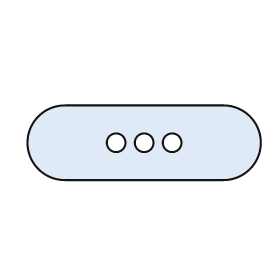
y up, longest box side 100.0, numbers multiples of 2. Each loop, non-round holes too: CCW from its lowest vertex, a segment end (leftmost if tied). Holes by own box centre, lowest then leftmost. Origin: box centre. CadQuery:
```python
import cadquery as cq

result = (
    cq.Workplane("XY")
    .moveTo(-34.0, -16.0)
    .lineTo(34.0, -16.0)
    .threePointArc((50.0, 0.0), (34.0, 16.0))
    .lineTo(-34.0, 16.0)
    .threePointArc((-50.0, 0.0), (-34.0, -16.0))
    .close()
    .moveTo(-12.0, 0.0)
    .circle(4.0)
    .moveTo(0.0, 0.0)
    .circle(4.0)
    .moveTo(12.0, 0.0)
    .circle(4.0)
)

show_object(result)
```